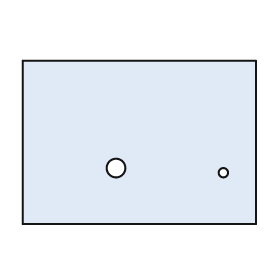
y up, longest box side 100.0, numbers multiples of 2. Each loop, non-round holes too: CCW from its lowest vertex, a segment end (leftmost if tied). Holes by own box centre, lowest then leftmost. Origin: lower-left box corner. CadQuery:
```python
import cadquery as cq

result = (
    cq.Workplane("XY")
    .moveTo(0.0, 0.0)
    .lineTo(100.0, 0.0)
    .lineTo(100.0, 70.0)
    .lineTo(0.0, 70.0)
    .close()
    .moveTo(86.0, 22.0)
    .circle(2.0)
    .moveTo(40.0, 24.0)
    .circle(4.0)
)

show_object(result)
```